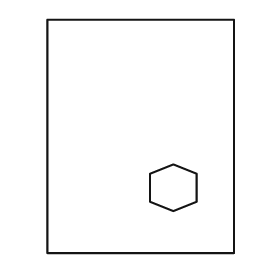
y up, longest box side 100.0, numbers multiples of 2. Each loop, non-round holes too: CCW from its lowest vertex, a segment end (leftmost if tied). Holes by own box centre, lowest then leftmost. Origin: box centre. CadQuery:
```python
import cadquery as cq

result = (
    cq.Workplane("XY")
    .moveTo(-40.0, -50.0)
    .lineTo(40.0, -50.0)
    .lineTo(40.0, 50.0)
    .lineTo(-40.0, 50.0)
    .close()
    .moveTo(14.0, -32.0)
    .lineTo(24.0, -28.0)
    .lineTo(24.0, -16.0)
    .lineTo(14.0, -12.0)
    .lineTo(4.0, -16.0)
    .lineTo(4.0, -28.0)
    .close()
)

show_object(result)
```